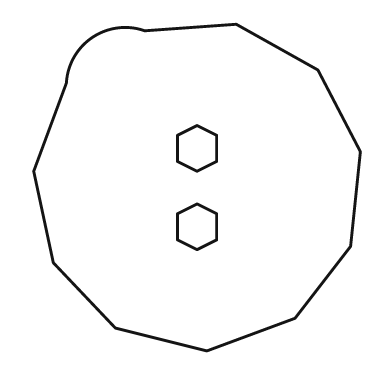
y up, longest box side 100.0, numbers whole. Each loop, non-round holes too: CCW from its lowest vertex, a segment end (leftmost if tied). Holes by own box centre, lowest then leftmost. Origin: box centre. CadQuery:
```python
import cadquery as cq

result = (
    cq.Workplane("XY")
    .moveTo(3.0, -50.0)
    .lineTo(30.0, -40.0)
    .lineTo(47.0, -18.0)
    .lineTo(50.0, 11.0)
    .lineTo(37.0, 36.0)
    .lineTo(12.0, 50.0)
    .lineTo(-16.0, 48.0)
    .threePointArc((-32.0, 46.0), (-40.0, 32.0))
    .lineTo(-50.0, 5.0)
    .lineTo(-44.0, -23.0)
    .lineTo(-25.0, -43.0)
    .close()
    .moveTo(0.0, -19.0)
    .lineTo(6.0, -16.0)
    .lineTo(6.0, -8.0)
    .lineTo(0.0, -5.0)
    .lineTo(-6.0, -8.0)
    .lineTo(-6.0, -16.0)
    .close()
    .moveTo(0.0, 5.0)
    .lineTo(6.0, 8.0)
    .lineTo(6.0, 16.0)
    .lineTo(0.0, 19.0)
    .lineTo(-6.0, 16.0)
    .lineTo(-6.0, 8.0)
    .close()
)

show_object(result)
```